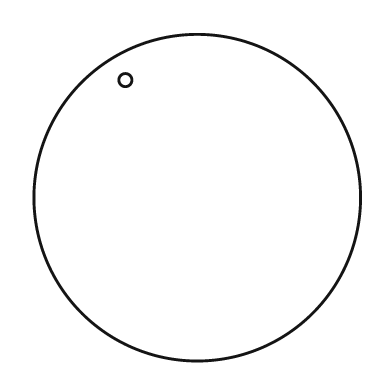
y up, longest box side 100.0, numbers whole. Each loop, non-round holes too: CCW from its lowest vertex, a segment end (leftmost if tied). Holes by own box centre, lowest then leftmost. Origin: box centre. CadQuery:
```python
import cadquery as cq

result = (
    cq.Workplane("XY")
    .moveTo(0.0, 0.0)
    .circle(50.0)
    .moveTo(-22.0, 36.0)
    .circle(2.0)
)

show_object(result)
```